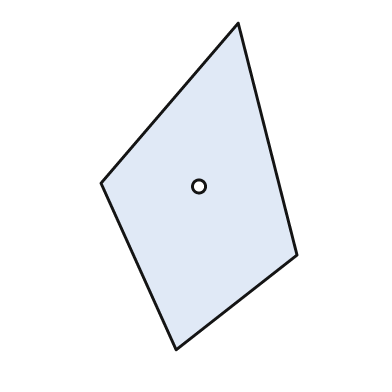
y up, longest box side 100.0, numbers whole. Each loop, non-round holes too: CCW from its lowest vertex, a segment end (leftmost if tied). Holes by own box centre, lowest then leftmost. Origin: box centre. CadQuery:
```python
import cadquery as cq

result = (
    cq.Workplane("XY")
    .moveTo(-7.0, -50.0)
    .lineTo(30.0, -21.0)
    .lineTo(12.0, 50.0)
    .lineTo(-30.0, 1.0)
    .close()
    .moveTo(0.0, 0.0)
    .circle(2.0)
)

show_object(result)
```